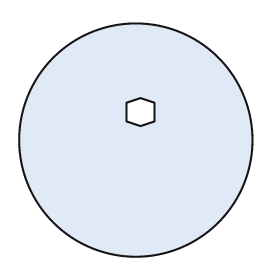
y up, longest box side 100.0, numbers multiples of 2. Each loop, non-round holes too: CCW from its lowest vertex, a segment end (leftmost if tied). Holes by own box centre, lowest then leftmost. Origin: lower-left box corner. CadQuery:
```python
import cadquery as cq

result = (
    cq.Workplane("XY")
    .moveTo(50.0, 50.0)
    .circle(50.0)
    .moveTo(52.0, 56.0)
    .lineTo(58.0, 58.0)
    .lineTo(58.0, 66.0)
    .lineTo(52.0, 68.0)
    .lineTo(46.0, 66.0)
    .lineTo(46.0, 58.0)
    .close()
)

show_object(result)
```